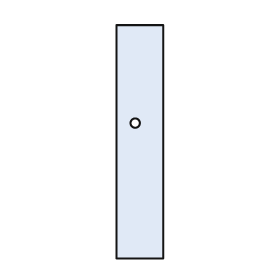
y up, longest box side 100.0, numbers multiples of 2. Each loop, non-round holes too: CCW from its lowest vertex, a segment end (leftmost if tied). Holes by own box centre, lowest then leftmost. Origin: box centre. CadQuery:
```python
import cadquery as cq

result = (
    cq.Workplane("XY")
    .moveTo(-10.0, -50.0)
    .lineTo(10.0, -50.0)
    .lineTo(10.0, 50.0)
    .lineTo(-10.0, 50.0)
    .close()
    .moveTo(-2.0, 8.0)
    .circle(2.0)
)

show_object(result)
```